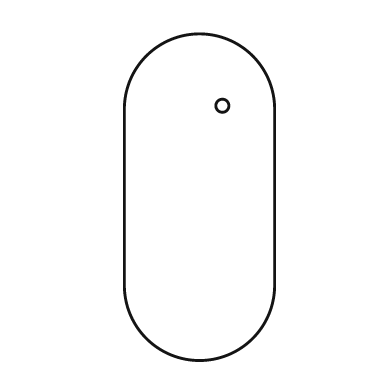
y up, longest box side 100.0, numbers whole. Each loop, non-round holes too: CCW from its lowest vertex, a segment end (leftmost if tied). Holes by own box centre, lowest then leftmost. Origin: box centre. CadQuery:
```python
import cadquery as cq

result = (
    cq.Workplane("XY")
    .moveTo(-23.0, -27.0)
    .threePointArc((0.0, -50.0), (23.0, -27.0))
    .lineTo(23.0, 27.0)
    .threePointArc((0.0, 50.0), (-23.0, 27.0))
    .close()
    .moveTo(7.0, 28.0)
    .circle(2.0)
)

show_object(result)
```